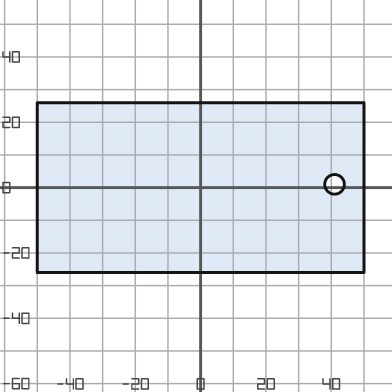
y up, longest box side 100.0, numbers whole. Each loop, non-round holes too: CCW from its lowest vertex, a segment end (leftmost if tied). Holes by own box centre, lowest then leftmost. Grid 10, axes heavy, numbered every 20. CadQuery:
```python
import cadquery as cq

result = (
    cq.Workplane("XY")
    .moveTo(-50.0, -26.0)
    .lineTo(50.0, -26.0)
    .lineTo(50.0, 26.0)
    .lineTo(-50.0, 26.0)
    .close()
    .moveTo(41.0, 1.0)
    .circle(3.0)
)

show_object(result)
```